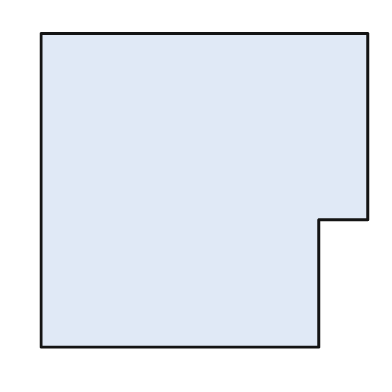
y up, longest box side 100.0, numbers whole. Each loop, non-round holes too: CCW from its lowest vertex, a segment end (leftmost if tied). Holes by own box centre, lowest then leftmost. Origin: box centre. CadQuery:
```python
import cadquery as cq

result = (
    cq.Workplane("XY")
    .moveTo(-50.0, -48.0)
    .lineTo(35.0, -48.0)
    .lineTo(35.0, -9.0)
    .lineTo(50.0, -9.0)
    .lineTo(50.0, 48.0)
    .lineTo(-50.0, 48.0)
    .close()
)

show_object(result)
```